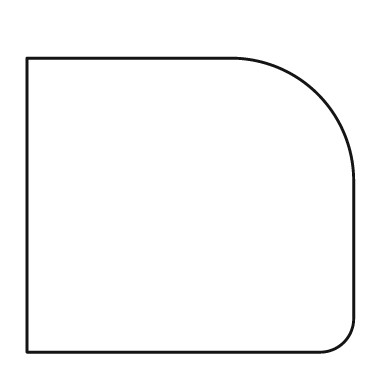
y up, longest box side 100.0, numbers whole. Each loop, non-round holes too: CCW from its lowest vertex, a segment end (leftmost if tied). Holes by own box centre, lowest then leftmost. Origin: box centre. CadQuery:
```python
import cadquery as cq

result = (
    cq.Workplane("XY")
    .moveTo(-50.0, -45.0)
    .lineTo(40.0, -45.0)
    .threePointArc((47.0, -42.0), (50.0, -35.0))
    .lineTo(50.0, 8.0)
    .threePointArc((39.0, 34.0), (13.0, 45.0))
    .lineTo(-50.0, 45.0)
    .close()
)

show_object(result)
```